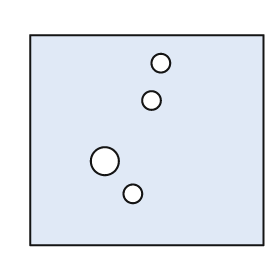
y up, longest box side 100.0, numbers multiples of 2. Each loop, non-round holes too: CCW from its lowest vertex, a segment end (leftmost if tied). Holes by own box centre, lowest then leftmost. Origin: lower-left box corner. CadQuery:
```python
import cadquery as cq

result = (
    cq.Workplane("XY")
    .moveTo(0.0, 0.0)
    .lineTo(100.0, 0.0)
    .lineTo(100.0, 90.0)
    .lineTo(0.0, 90.0)
    .close()
    .moveTo(44.0, 22.0)
    .circle(4.0)
    .moveTo(32.0, 36.0)
    .circle(6.0)
    .moveTo(52.0, 62.0)
    .circle(4.0)
    .moveTo(56.0, 78.0)
    .circle(4.0)
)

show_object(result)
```